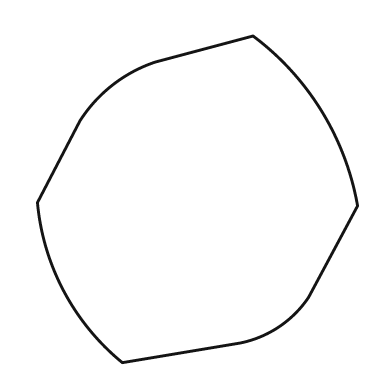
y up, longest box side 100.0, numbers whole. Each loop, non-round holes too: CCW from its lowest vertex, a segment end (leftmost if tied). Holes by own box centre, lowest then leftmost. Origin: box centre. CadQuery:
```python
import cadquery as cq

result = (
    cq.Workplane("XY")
    .moveTo(-23.0, -50.0)
    .lineTo(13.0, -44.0)
    .threePointArc((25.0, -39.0), (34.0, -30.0))
    .lineTo(49.0, -2.0)
    .threePointArc((38.0, 27.0), (17.0, 50.0))
    .lineTo(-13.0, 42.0)
    .threePointArc((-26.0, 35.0), (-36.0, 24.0))
    .lineTo(-49.0, -1.0)
    .threePointArc((-41.0, -28.0), (-23.0, -50.0))
    .close()
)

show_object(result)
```